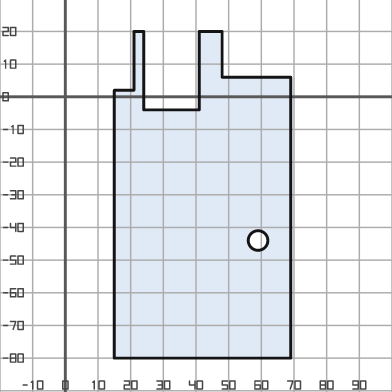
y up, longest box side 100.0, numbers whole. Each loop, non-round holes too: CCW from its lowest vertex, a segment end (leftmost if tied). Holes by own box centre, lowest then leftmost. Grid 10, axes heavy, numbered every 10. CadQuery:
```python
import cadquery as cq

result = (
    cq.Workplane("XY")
    .moveTo(15.0, -80.0)
    .lineTo(69.0, -80.0)
    .lineTo(69.0, 6.0)
    .lineTo(48.0, 6.0)
    .lineTo(48.0, 20.0)
    .lineTo(41.0, 20.0)
    .lineTo(41.0, -4.0)
    .lineTo(24.0, -4.0)
    .lineTo(24.0, 20.0)
    .lineTo(21.0, 20.0)
    .lineTo(21.0, 2.0)
    .lineTo(15.0, 2.0)
    .close()
    .moveTo(59.0, -44.0)
    .circle(3.0)
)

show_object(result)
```